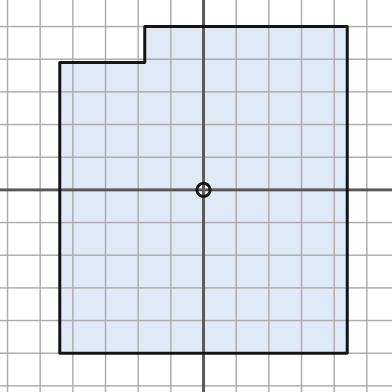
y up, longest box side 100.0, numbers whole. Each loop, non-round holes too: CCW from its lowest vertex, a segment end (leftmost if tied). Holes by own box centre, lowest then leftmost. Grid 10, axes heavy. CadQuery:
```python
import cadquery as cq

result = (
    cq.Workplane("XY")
    .moveTo(-44.0, -50.0)
    .lineTo(44.0, -50.0)
    .lineTo(44.0, 50.0)
    .lineTo(-18.0, 50.0)
    .lineTo(-18.0, 39.0)
    .lineTo(-44.0, 39.0)
    .close()
    .moveTo(0.0, 0.0)
    .circle(2.0)
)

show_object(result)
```